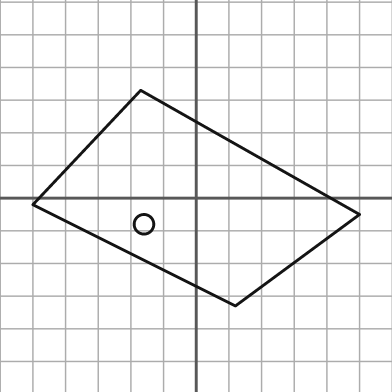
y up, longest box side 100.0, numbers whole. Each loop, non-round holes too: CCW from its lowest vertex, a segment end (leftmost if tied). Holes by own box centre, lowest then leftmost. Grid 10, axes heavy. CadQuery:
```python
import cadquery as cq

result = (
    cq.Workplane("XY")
    .moveTo(12.0, -33.0)
    .lineTo(50.0, -5.0)
    .lineTo(-17.0, 33.0)
    .lineTo(-50.0, -2.0)
    .close()
    .moveTo(-16.0, -8.0)
    .circle(3.0)
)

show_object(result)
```